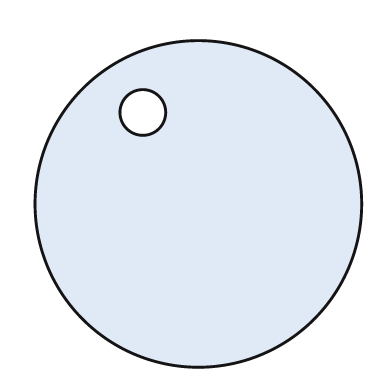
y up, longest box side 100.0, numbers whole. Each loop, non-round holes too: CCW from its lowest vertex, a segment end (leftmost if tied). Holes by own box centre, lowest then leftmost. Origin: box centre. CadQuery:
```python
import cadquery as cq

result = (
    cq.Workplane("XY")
    .moveTo(0.0, 0.0)
    .circle(50.0)
    .moveTo(-17.0, 28.0)
    .circle(7.0)
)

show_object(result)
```